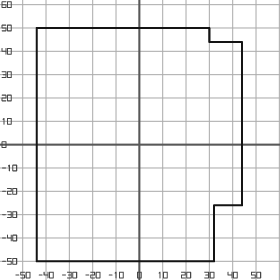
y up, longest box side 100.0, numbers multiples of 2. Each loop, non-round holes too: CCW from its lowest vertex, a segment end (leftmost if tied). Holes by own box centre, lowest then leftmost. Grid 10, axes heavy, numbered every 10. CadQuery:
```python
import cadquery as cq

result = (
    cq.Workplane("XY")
    .moveTo(-44.0, -50.0)
    .lineTo(32.0, -50.0)
    .lineTo(32.0, -26.0)
    .lineTo(44.0, -26.0)
    .lineTo(44.0, 44.0)
    .lineTo(30.0, 44.0)
    .lineTo(30.0, 50.0)
    .lineTo(-44.0, 50.0)
    .close()
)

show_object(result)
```